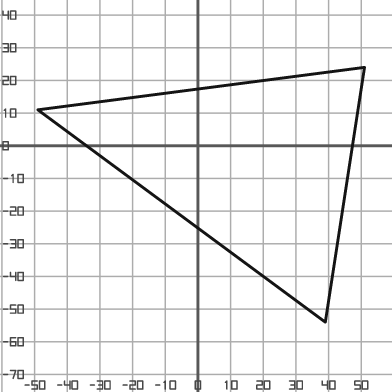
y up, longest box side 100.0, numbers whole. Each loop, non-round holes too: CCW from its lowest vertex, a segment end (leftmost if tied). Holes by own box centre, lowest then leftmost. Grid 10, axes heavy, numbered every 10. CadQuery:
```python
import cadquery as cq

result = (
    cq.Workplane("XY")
    .moveTo(39.0, -54.0)
    .lineTo(51.0, 24.0)
    .lineTo(-49.0, 11.0)
    .close()
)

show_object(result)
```